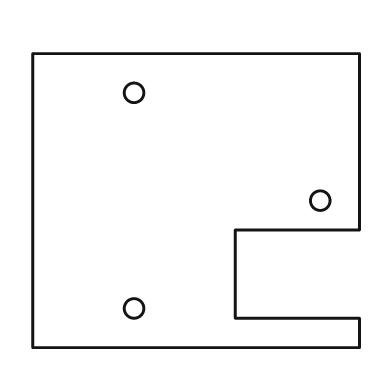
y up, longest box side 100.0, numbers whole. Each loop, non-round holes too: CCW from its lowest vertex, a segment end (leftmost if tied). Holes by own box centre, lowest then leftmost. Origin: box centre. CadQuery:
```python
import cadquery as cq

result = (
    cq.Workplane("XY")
    .moveTo(-50.0, -45.0)
    .lineTo(50.0, -45.0)
    .lineTo(50.0, -36.0)
    .lineTo(12.0, -36.0)
    .lineTo(12.0, -9.0)
    .lineTo(50.0, -9.0)
    .lineTo(50.0, 45.0)
    .lineTo(-50.0, 45.0)
    .close()
    .moveTo(-19.0, -33.0)
    .circle(3.0)
    .moveTo(38.0, 0.0)
    .circle(3.0)
    .moveTo(-19.0, 33.0)
    .circle(3.0)
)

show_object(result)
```